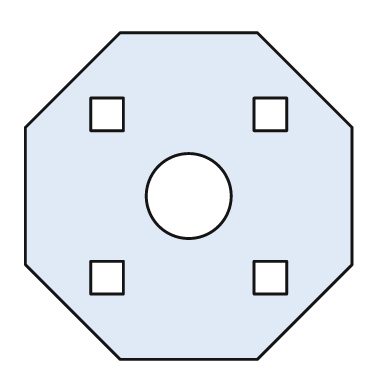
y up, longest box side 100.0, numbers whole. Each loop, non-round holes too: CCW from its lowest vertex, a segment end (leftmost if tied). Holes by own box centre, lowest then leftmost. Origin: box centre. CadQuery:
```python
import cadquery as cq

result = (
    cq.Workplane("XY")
    .moveTo(-21.0, -50.0)
    .lineTo(21.0, -50.0)
    .lineTo(50.0, -21.0)
    .lineTo(50.0, 21.0)
    .lineTo(21.0, 50.0)
    .lineTo(-21.0, 50.0)
    .lineTo(-50.0, 21.0)
    .lineTo(-50.0, -21.0)
    .close()
    .moveTo(-30.0, -30.0)
    .lineTo(-20.0, -30.0)
    .lineTo(-20.0, -20.0)
    .lineTo(-30.0, -20.0)
    .close()
    .moveTo(20.0, -30.0)
    .lineTo(30.0, -30.0)
    .lineTo(30.0, -20.0)
    .lineTo(20.0, -20.0)
    .close()
    .moveTo(0.0, 0.0)
    .circle(13.0)
    .moveTo(-30.0, 20.0)
    .lineTo(-20.0, 20.0)
    .lineTo(-20.0, 30.0)
    .lineTo(-30.0, 30.0)
    .close()
    .moveTo(20.0, 20.0)
    .lineTo(30.0, 20.0)
    .lineTo(30.0, 30.0)
    .lineTo(20.0, 30.0)
    .close()
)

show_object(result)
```